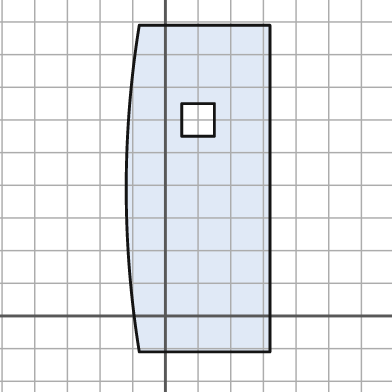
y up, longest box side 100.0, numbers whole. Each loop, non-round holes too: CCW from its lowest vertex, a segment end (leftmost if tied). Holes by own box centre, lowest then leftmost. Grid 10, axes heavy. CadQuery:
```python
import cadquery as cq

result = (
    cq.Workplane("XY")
    .moveTo(-8.0, -11.0)
    .lineTo(32.0, -11.0)
    .lineTo(32.0, 89.0)
    .lineTo(-8.0, 89.0)
    .threePointArc((-12.0, 39.0), (-8.0, -11.0))
    .close()
    .moveTo(5.0, 55.0)
    .lineTo(15.0, 55.0)
    .lineTo(15.0, 65.0)
    .lineTo(5.0, 65.0)
    .close()
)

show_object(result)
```